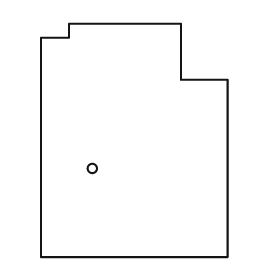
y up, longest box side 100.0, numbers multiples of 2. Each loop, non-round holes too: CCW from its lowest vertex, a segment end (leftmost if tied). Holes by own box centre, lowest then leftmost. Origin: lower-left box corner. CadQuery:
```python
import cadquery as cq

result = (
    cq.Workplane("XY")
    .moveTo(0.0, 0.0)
    .lineTo(80.0, 0.0)
    .lineTo(80.0, 76.0)
    .lineTo(60.0, 76.0)
    .lineTo(60.0, 100.0)
    .lineTo(12.0, 100.0)
    .lineTo(12.0, 94.0)
    .lineTo(0.0, 94.0)
    .close()
    .moveTo(22.0, 38.0)
    .circle(2.0)
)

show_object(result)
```